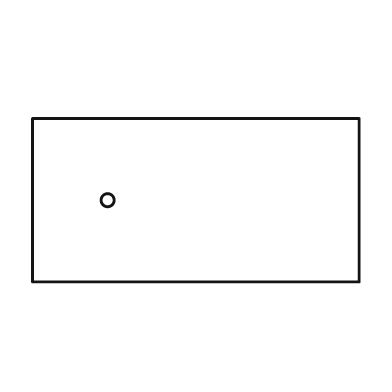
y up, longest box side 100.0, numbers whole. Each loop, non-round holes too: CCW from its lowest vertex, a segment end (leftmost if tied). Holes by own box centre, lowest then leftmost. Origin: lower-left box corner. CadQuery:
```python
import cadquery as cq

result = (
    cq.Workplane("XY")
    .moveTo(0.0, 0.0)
    .lineTo(100.0, 0.0)
    .lineTo(100.0, 50.0)
    .lineTo(0.0, 50.0)
    .close()
    .moveTo(23.0, 25.0)
    .circle(2.0)
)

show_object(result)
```